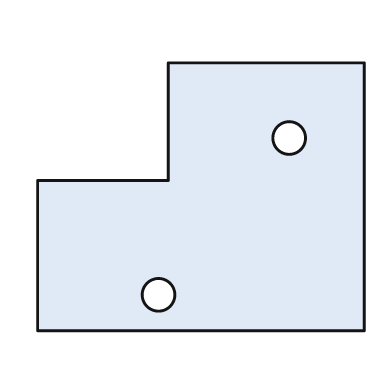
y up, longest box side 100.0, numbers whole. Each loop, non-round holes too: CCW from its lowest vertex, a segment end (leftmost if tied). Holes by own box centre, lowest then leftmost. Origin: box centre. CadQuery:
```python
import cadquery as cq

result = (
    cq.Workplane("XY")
    .moveTo(-50.0, -41.0)
    .lineTo(50.0, -41.0)
    .lineTo(50.0, 41.0)
    .lineTo(-10.0, 41.0)
    .lineTo(-10.0, 5.0)
    .lineTo(-50.0, 5.0)
    .close()
    .moveTo(-13.0, -30.0)
    .circle(5.0)
    .moveTo(27.0, 18.0)
    .circle(5.0)
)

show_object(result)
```